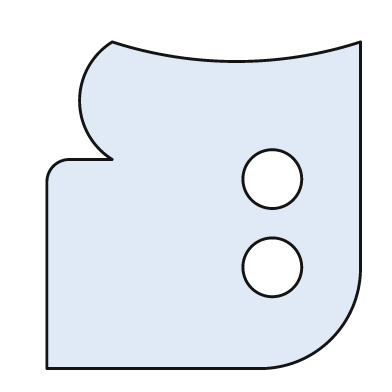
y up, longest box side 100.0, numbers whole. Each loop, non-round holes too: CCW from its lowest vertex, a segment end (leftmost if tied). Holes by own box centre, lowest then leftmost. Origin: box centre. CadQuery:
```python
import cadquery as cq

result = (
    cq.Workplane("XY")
    .moveTo(-48.0, -50.0)
    .lineTo(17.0, -50.0)
    .threePointArc((39.0, -41.0), (48.0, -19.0))
    .lineTo(48.0, 50.0)
    .threePointArc((10.0, 44.0), (-28.0, 50.0))
    .threePointArc((-38.0, 32.0), (-28.0, 14.0))
    .lineTo(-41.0, 14.0)
    .threePointArc((-46.0, 12.0), (-48.0, 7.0))
    .close()
    .moveTo(21.0, -19.0)
    .circle(9.0)
    .moveTo(21.0, 8.0)
    .circle(9.0)
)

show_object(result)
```